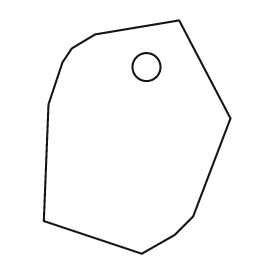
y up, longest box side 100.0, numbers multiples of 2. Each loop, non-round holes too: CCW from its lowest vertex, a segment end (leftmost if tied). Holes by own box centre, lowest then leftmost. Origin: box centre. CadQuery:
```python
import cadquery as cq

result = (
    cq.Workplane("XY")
    .moveTo(2.0, -50.0)
    .lineTo(16.0, -42.0)
    .lineTo(24.0, -34.0)
    .lineTo(40.0, 8.0)
    .lineTo(18.0, 50.0)
    .lineTo(-18.0, 44.0)
    .lineTo(-28.0, 38.0)
    .lineTo(-32.0, 32.0)
    .lineTo(-38.0, 14.0)
    .lineTo(-40.0, -36.0)
    .close()
    .moveTo(4.0, 30.0)
    .circle(6.0)
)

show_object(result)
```